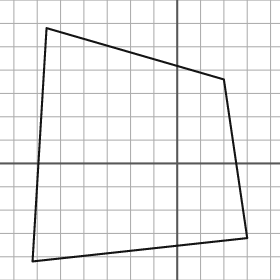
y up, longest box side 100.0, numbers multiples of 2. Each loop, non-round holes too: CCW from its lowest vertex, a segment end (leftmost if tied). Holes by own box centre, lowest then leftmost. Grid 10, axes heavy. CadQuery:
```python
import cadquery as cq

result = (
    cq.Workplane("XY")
    .moveTo(-62.0, -42.0)
    .lineTo(30.0, -32.0)
    .lineTo(20.0, 36.0)
    .lineTo(-56.0, 58.0)
    .close()
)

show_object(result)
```